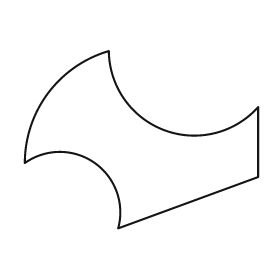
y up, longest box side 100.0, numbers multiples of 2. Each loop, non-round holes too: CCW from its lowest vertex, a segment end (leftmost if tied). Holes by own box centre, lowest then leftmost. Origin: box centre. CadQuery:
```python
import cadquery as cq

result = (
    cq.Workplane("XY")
    .moveTo(-10.0, -38.0)
    .lineTo(50.0, -16.0)
    .lineTo(50.0, 14.0)
    .threePointArc((10.0, 4.0), (-14.0, 38.0))
    .threePointArc((-40.0, 20.0), (-50.0, -10.0))
    .threePointArc((-20.0, -10.0), (-10.0, -38.0))
    .close()
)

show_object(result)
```